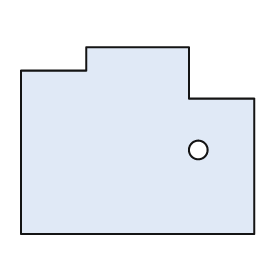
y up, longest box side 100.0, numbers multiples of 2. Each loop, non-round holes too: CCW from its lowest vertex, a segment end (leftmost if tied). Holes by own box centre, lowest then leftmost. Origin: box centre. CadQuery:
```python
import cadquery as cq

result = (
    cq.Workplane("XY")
    .moveTo(-50.0, -40.0)
    .lineTo(50.0, -40.0)
    .lineTo(50.0, 18.0)
    .lineTo(22.0, 18.0)
    .lineTo(22.0, 40.0)
    .lineTo(-22.0, 40.0)
    .lineTo(-22.0, 30.0)
    .lineTo(-50.0, 30.0)
    .close()
    .moveTo(26.0, -4.0)
    .circle(4.0)
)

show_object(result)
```